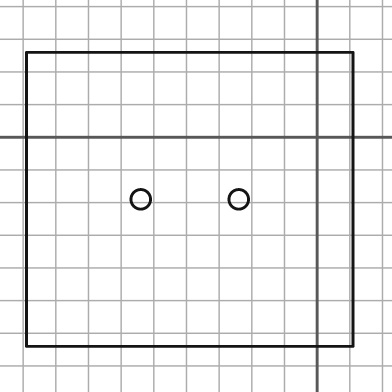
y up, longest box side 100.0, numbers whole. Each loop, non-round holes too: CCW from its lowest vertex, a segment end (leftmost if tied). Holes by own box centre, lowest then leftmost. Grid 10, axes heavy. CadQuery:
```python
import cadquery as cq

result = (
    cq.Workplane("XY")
    .moveTo(-89.0, -64.0)
    .lineTo(11.0, -64.0)
    .lineTo(11.0, 26.0)
    .lineTo(-89.0, 26.0)
    .close()
    .moveTo(-54.0, -19.0)
    .circle(3.0)
    .moveTo(-24.0, -19.0)
    .circle(3.0)
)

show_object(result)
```